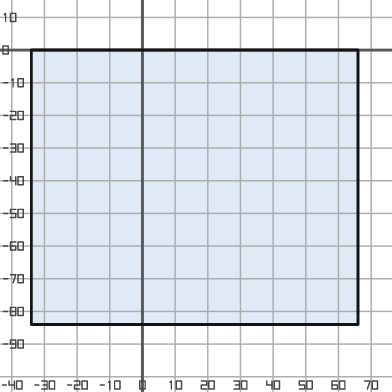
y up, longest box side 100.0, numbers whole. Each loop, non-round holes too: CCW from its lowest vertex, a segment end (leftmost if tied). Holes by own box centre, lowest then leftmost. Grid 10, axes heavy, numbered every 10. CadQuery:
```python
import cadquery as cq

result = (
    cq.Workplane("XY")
    .moveTo(-34.0, -84.0)
    .lineTo(66.0, -84.0)
    .lineTo(66.0, 0.0)
    .lineTo(-34.0, 0.0)
    .close()
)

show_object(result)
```